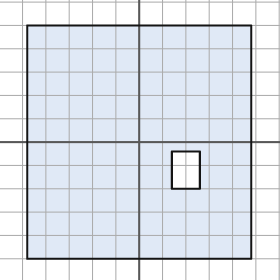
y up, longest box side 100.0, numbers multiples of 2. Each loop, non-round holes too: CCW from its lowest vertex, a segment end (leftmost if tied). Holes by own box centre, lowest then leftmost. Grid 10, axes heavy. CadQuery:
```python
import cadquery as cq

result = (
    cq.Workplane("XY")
    .moveTo(-48.0, -50.0)
    .lineTo(48.0, -50.0)
    .lineTo(48.0, 50.0)
    .lineTo(-48.0, 50.0)
    .close()
    .moveTo(14.0, -20.0)
    .lineTo(26.0, -20.0)
    .lineTo(26.0, -4.0)
    .lineTo(14.0, -4.0)
    .close()
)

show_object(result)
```